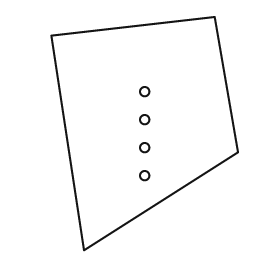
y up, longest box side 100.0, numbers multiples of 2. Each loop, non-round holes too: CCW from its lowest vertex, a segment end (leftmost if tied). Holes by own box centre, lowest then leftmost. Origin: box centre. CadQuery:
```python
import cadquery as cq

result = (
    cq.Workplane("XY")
    .moveTo(-26.0, -50.0)
    .lineTo(40.0, -8.0)
    .lineTo(30.0, 50.0)
    .lineTo(-40.0, 42.0)
    .close()
    .moveTo(0.0, -18.0)
    .circle(2.0)
    .moveTo(0.0, -6.0)
    .circle(2.0)
    .moveTo(0.0, 6.0)
    .circle(2.0)
    .moveTo(0.0, 18.0)
    .circle(2.0)
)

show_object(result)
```